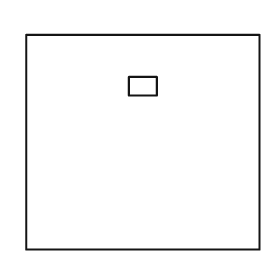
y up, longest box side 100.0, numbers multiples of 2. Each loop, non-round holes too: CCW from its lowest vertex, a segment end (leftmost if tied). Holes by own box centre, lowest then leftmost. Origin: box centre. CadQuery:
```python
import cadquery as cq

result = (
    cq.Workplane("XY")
    .moveTo(-50.0, -46.0)
    .lineTo(50.0, -46.0)
    .lineTo(50.0, 46.0)
    .lineTo(-50.0, 46.0)
    .close()
    .moveTo(-6.0, 20.0)
    .lineTo(6.0, 20.0)
    .lineTo(6.0, 28.0)
    .lineTo(-6.0, 28.0)
    .close()
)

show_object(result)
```